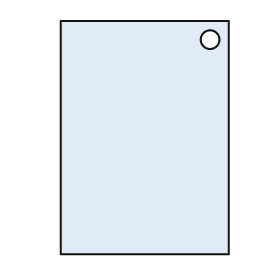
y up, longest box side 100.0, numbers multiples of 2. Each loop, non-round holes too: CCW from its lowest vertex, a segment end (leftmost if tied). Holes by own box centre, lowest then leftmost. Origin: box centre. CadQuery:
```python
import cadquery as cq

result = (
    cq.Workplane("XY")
    .moveTo(-36.0, -50.0)
    .lineTo(36.0, -50.0)
    .lineTo(36.0, 50.0)
    .lineTo(-36.0, 50.0)
    .close()
    .moveTo(28.0, 42.0)
    .circle(4.0)
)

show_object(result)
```